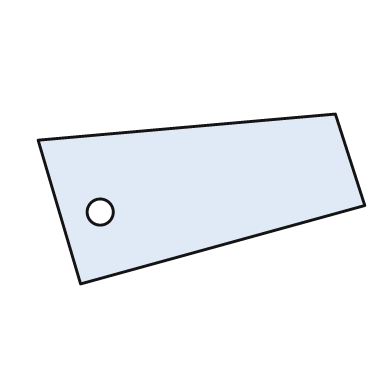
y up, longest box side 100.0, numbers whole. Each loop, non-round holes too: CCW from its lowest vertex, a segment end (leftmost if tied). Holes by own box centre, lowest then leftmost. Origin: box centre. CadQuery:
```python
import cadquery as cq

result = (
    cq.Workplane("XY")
    .moveTo(-37.0, -26.0)
    .lineTo(50.0, -2.0)
    .lineTo(41.0, 26.0)
    .lineTo(-50.0, 18.0)
    .close()
    .moveTo(-31.0, -4.0)
    .circle(4.0)
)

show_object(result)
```